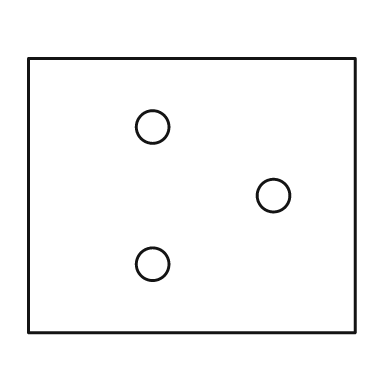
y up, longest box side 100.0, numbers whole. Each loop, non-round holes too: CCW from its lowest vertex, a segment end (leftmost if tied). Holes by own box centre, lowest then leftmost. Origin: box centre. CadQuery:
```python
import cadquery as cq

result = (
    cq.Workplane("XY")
    .moveTo(-50.0, -42.0)
    .lineTo(50.0, -42.0)
    .lineTo(50.0, 42.0)
    .lineTo(-50.0, 42.0)
    .close()
    .moveTo(-12.0, -21.0)
    .circle(5.0)
    .moveTo(25.0, 0.0)
    .circle(5.0)
    .moveTo(-12.0, 21.0)
    .circle(5.0)
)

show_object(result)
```